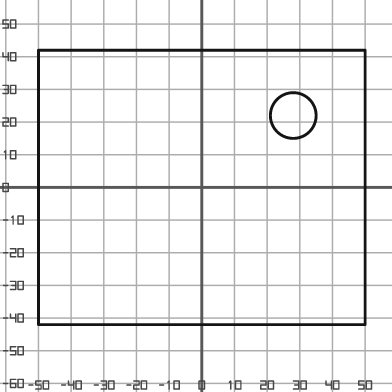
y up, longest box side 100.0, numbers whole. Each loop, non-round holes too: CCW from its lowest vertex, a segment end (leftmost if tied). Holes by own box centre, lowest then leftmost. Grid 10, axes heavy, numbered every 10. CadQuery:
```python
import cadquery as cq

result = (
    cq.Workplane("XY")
    .moveTo(-50.0, -42.0)
    .lineTo(50.0, -42.0)
    .lineTo(50.0, 42.0)
    .lineTo(-50.0, 42.0)
    .close()
    .moveTo(28.0, 22.0)
    .circle(7.0)
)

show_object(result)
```